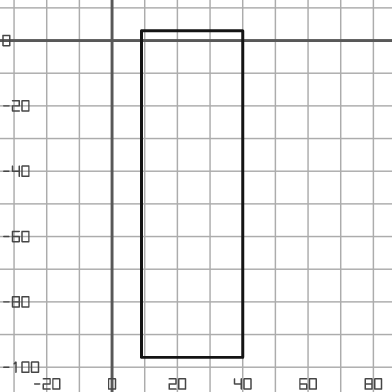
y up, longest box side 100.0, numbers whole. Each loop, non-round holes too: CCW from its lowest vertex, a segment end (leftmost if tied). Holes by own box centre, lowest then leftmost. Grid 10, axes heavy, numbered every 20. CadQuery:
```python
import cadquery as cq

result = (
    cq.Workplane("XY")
    .moveTo(9.0, -97.0)
    .lineTo(40.0, -97.0)
    .lineTo(40.0, 3.0)
    .lineTo(9.0, 3.0)
    .close()
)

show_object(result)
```